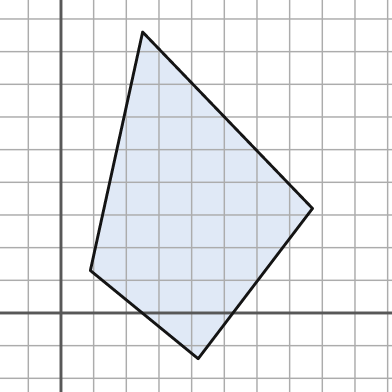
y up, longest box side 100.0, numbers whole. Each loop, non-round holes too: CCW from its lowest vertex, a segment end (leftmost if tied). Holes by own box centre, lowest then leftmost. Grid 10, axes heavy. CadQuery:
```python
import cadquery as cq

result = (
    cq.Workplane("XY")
    .moveTo(42.0, -14.0)
    .lineTo(77.0, 32.0)
    .lineTo(25.0, 86.0)
    .lineTo(9.0, 13.0)
    .close()
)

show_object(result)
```